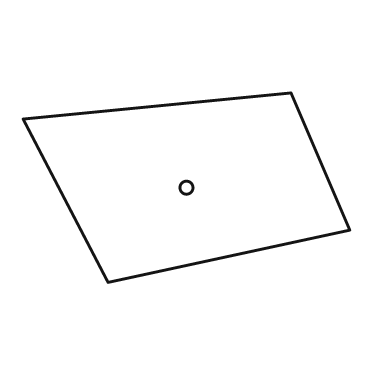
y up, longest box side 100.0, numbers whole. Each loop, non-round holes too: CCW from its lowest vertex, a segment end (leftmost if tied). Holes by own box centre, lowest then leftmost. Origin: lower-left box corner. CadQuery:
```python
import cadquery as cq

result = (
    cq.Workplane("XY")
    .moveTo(26.0, 0.0)
    .lineTo(100.0, 16.0)
    .lineTo(82.0, 58.0)
    .lineTo(0.0, 50.0)
    .close()
    .moveTo(50.0, 29.0)
    .circle(2.0)
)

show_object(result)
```